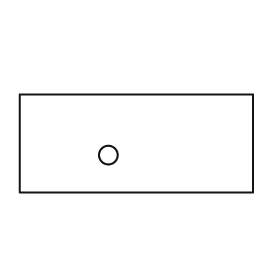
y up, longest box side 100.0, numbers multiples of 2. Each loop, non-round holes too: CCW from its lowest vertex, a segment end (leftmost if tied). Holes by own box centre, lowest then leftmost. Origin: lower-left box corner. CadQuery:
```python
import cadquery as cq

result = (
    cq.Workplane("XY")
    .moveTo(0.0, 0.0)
    .lineTo(100.0, 0.0)
    .lineTo(100.0, 42.0)
    .lineTo(0.0, 42.0)
    .close()
    .moveTo(38.0, 16.0)
    .circle(4.0)
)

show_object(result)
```